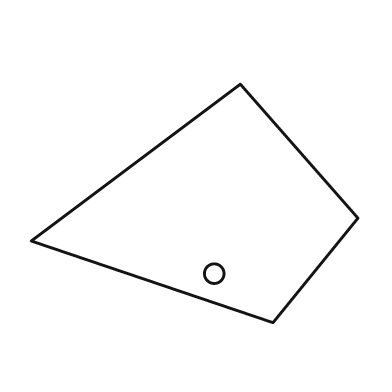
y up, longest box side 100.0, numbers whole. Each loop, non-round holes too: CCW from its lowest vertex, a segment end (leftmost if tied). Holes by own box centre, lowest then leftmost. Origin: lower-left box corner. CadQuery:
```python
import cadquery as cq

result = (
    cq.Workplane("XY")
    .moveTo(74.0, 0.0)
    .lineTo(100.0, 32.0)
    .lineTo(64.0, 73.0)
    .lineTo(0.0, 25.0)
    .close()
    .moveTo(56.0, 15.0)
    .circle(3.0)
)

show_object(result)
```